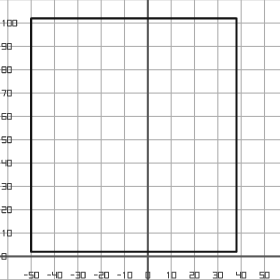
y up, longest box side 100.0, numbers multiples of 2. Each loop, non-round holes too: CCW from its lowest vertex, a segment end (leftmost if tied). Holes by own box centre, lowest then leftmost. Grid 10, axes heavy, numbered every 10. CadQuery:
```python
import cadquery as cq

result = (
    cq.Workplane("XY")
    .moveTo(-50.0, 2.0)
    .lineTo(38.0, 2.0)
    .lineTo(38.0, 102.0)
    .lineTo(-50.0, 102.0)
    .close()
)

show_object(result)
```